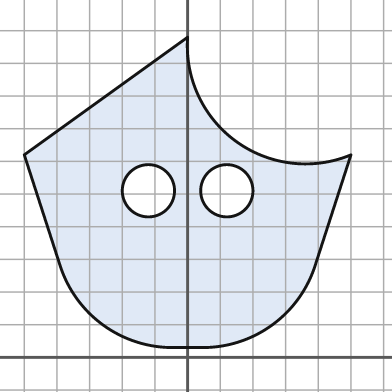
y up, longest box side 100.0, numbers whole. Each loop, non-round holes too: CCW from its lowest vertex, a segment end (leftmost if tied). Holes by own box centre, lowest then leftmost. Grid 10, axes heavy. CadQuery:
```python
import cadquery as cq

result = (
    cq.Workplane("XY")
    .moveTo(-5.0, 3.0)
    .lineTo(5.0, 3.0)
    .threePointArc((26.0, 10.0), (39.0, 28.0))
    .lineTo(50.0, 62.0)
    .threePointArc((15.0, 66.0), (0.0, 98.0))
    .lineTo(-50.0, 62.0)
    .lineTo(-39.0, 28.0)
    .threePointArc((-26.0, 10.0), (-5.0, 3.0))
    .close()
    .moveTo(-12.0, 51.0)
    .circle(8.0)
    .moveTo(12.0, 51.0)
    .circle(8.0)
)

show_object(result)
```